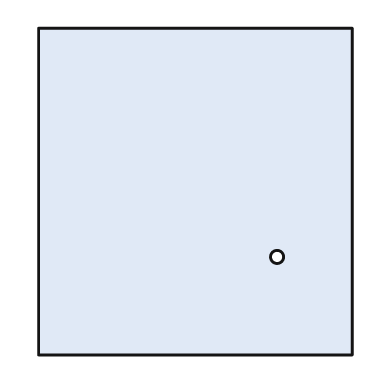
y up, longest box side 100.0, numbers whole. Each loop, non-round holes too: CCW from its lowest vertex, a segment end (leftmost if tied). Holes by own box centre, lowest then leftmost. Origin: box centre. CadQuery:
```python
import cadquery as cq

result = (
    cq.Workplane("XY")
    .moveTo(-48.0, -50.0)
    .lineTo(48.0, -50.0)
    .lineTo(48.0, 50.0)
    .lineTo(-48.0, 50.0)
    .close()
    .moveTo(25.0, -20.0)
    .circle(2.0)
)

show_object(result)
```